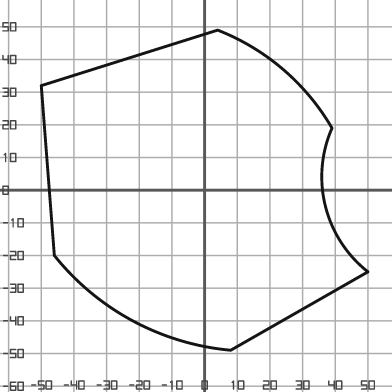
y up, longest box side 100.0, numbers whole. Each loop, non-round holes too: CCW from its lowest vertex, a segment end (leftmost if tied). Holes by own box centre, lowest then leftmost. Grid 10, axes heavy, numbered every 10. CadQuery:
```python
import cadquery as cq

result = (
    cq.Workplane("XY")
    .moveTo(8.0, -49.0)
    .lineTo(50.0, -25.0)
    .threePointArc((37.0, -5.0), (39.0, 19.0))
    .threePointArc((24.0, 37.0), (4.0, 49.0))
    .lineTo(-50.0, 32.0)
    .lineTo(-46.0, -20.0)
    .threePointArc((-22.0, -40.0), (8.0, -49.0))
    .close()
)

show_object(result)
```